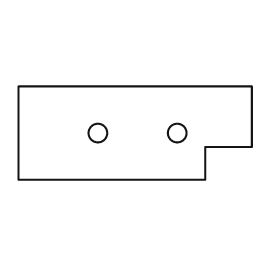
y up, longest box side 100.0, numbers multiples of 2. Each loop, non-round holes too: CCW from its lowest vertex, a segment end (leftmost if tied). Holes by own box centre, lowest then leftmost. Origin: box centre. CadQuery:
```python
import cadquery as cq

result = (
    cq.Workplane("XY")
    .moveTo(-50.0, -20.0)
    .lineTo(30.0, -20.0)
    .lineTo(30.0, -6.0)
    .lineTo(50.0, -6.0)
    .lineTo(50.0, 20.0)
    .lineTo(-50.0, 20.0)
    .close()
    .moveTo(-16.0, 0.0)
    .circle(4.0)
    .moveTo(18.0, 0.0)
    .circle(4.0)
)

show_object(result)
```